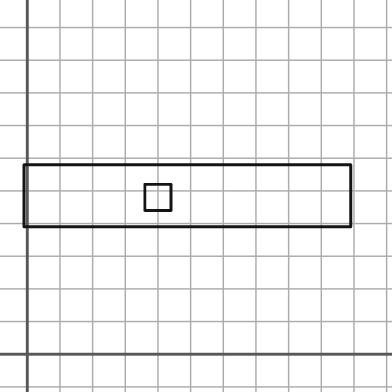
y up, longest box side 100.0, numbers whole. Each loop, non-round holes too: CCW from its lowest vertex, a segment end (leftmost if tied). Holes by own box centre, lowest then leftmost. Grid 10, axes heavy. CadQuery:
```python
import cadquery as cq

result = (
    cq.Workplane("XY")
    .moveTo(-1.0, 39.0)
    .lineTo(99.0, 39.0)
    .lineTo(99.0, 58.0)
    .lineTo(-1.0, 58.0)
    .close()
    .moveTo(36.0, 44.0)
    .lineTo(44.0, 44.0)
    .lineTo(44.0, 52.0)
    .lineTo(36.0, 52.0)
    .close()
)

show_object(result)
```